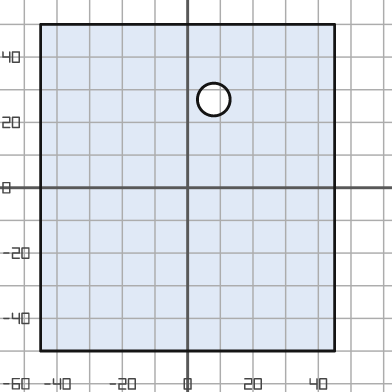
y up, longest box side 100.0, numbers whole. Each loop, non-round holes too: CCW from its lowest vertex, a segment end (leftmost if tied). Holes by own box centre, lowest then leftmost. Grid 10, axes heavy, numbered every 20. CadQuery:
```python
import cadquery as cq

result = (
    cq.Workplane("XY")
    .moveTo(-45.0, -50.0)
    .lineTo(45.0, -50.0)
    .lineTo(45.0, 50.0)
    .lineTo(-45.0, 50.0)
    .close()
    .moveTo(8.0, 27.0)
    .circle(5.0)
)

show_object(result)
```